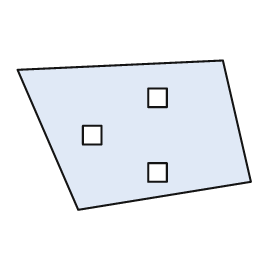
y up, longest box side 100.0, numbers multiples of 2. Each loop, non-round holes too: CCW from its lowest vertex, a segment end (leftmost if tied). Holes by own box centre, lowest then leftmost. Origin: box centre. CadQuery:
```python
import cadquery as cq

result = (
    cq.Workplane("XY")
    .moveTo(-24.0, -32.0)
    .lineTo(50.0, -20.0)
    .lineTo(38.0, 32.0)
    .lineTo(-50.0, 28.0)
    .close()
    .moveTo(6.0, -20.0)
    .lineTo(14.0, -20.0)
    .lineTo(14.0, -12.0)
    .lineTo(6.0, -12.0)
    .close()
    .moveTo(-22.0, -4.0)
    .lineTo(-14.0, -4.0)
    .lineTo(-14.0, 4.0)
    .lineTo(-22.0, 4.0)
    .close()
    .moveTo(6.0, 12.0)
    .lineTo(14.0, 12.0)
    .lineTo(14.0, 20.0)
    .lineTo(6.0, 20.0)
    .close()
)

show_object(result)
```